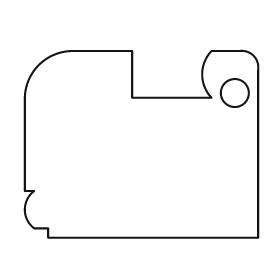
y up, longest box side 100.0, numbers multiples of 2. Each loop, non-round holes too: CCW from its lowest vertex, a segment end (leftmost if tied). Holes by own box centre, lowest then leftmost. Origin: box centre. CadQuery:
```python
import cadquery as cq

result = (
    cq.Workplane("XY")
    .moveTo(-40.0, -40.0)
    .lineTo(50.0, -40.0)
    .lineTo(50.0, 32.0)
    .threePointArc((48.0, 38.0), (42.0, 40.0))
    .lineTo(30.0, 40.0)
    .threePointArc((26.0, 30.0), (30.0, 20.0))
    .lineTo(-4.0, 20.0)
    .lineTo(-4.0, 40.0)
    .lineTo(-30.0, 40.0)
    .threePointArc((-44.0, 34.0), (-50.0, 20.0))
    .lineTo(-50.0, -20.0)
    .lineTo(-46.0, -20.0)
    .threePointArc((-50.0, -28.0), (-46.0, -36.0))
    .lineTo(-40.0, -36.0)
    .close()
    .moveTo(40.0, 22.0)
    .circle(6.0)
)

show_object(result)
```